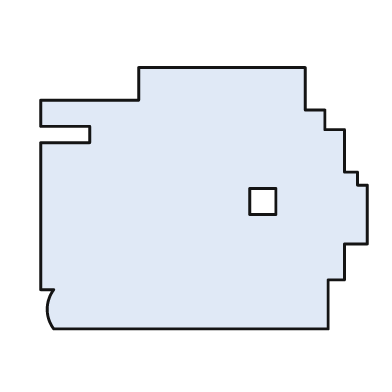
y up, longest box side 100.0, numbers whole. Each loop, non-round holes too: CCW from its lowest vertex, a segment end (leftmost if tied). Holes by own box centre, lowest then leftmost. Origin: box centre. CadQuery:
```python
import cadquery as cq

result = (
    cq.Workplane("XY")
    .moveTo(-46.0, -40.0)
    .lineTo(38.0, -40.0)
    .lineTo(38.0, -25.0)
    .lineTo(43.0, -25.0)
    .lineTo(43.0, -14.0)
    .lineTo(50.0, -14.0)
    .lineTo(50.0, 4.0)
    .lineTo(47.0, 4.0)
    .lineTo(47.0, 8.0)
    .lineTo(43.0, 8.0)
    .lineTo(43.0, 21.0)
    .lineTo(37.0, 21.0)
    .lineTo(37.0, 27.0)
    .lineTo(31.0, 27.0)
    .lineTo(31.0, 40.0)
    .lineTo(-20.0, 40.0)
    .lineTo(-20.0, 30.0)
    .lineTo(-50.0, 30.0)
    .lineTo(-50.0, 22.0)
    .lineTo(-35.0, 22.0)
    .lineTo(-35.0, 17.0)
    .lineTo(-50.0, 17.0)
    .lineTo(-50.0, -28.0)
    .lineTo(-46.0, -28.0)
    .threePointArc((-48.0, -34.0), (-46.0, -40.0))
    .close()
    .moveTo(14.0, -5.0)
    .lineTo(22.0, -5.0)
    .lineTo(22.0, 3.0)
    .lineTo(14.0, 3.0)
    .close()
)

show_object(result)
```